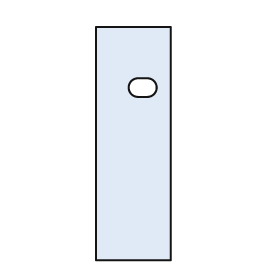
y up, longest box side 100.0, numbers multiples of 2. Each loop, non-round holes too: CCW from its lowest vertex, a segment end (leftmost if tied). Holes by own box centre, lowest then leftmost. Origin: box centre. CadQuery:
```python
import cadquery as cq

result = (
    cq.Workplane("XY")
    .moveTo(-16.0, -50.0)
    .lineTo(16.0, -50.0)
    .lineTo(16.0, 50.0)
    .lineTo(-16.0, 50.0)
    .close()
    .moveTo(2.0, 20.0)
    .lineTo(6.0, 20.0)
    .threePointArc((10.0, 24.0), (6.0, 28.0))
    .lineTo(2.0, 28.0)
    .threePointArc((-2.0, 24.0), (2.0, 20.0))
    .close()
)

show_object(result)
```